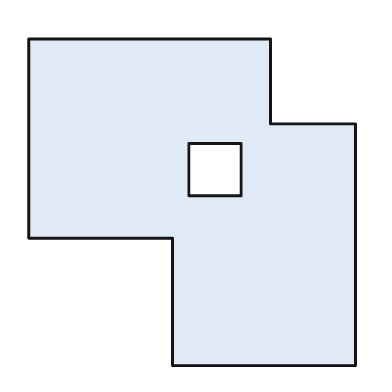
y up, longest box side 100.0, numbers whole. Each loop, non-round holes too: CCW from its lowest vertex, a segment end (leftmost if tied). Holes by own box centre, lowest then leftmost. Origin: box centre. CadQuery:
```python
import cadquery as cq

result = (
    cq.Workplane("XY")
    .moveTo(-6.0, -50.0)
    .lineTo(50.0, -50.0)
    .lineTo(50.0, 24.0)
    .lineTo(24.0, 24.0)
    .lineTo(24.0, 50.0)
    .lineTo(-50.0, 50.0)
    .lineTo(-50.0, -11.0)
    .lineTo(-6.0, -11.0)
    .close()
    .moveTo(-1.0, 2.0)
    .lineTo(15.0, 2.0)
    .lineTo(15.0, 18.0)
    .lineTo(-1.0, 18.0)
    .close()
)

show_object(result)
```